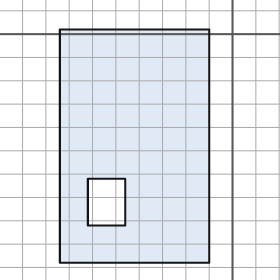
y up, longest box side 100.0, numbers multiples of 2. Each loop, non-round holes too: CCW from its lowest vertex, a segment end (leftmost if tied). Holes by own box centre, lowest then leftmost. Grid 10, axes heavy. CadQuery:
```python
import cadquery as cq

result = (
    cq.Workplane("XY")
    .moveTo(-74.0, -98.0)
    .lineTo(-10.0, -98.0)
    .lineTo(-10.0, 2.0)
    .lineTo(-74.0, 2.0)
    .close()
    .moveTo(-62.0, -82.0)
    .lineTo(-46.0, -82.0)
    .lineTo(-46.0, -62.0)
    .lineTo(-62.0, -62.0)
    .close()
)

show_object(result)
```